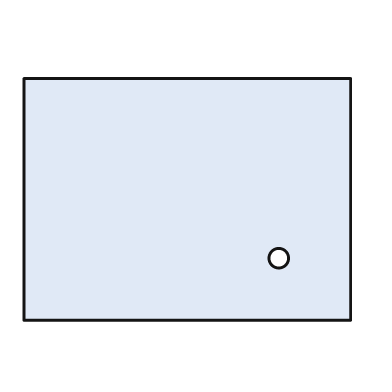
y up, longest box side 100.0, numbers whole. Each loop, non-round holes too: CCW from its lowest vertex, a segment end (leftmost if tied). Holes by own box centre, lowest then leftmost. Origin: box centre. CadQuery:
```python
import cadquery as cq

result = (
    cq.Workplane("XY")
    .moveTo(-50.0, -37.0)
    .lineTo(50.0, -37.0)
    .lineTo(50.0, 37.0)
    .lineTo(-50.0, 37.0)
    .close()
    .moveTo(28.0, -18.0)
    .circle(3.0)
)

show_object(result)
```